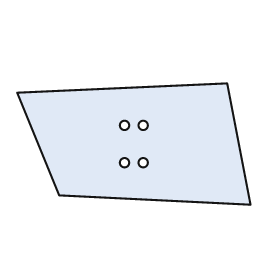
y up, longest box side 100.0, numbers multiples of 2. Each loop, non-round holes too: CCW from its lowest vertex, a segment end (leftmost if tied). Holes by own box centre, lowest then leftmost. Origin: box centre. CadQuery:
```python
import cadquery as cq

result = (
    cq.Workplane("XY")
    .moveTo(50.0, -26.0)
    .lineTo(40.0, 26.0)
    .lineTo(-50.0, 22.0)
    .lineTo(-32.0, -22.0)
    .close()
    .moveTo(-4.0, -8.0)
    .circle(2.0)
    .moveTo(4.0, -8.0)
    .circle(2.0)
    .moveTo(-4.0, 8.0)
    .circle(2.0)
    .moveTo(4.0, 8.0)
    .circle(2.0)
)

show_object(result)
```